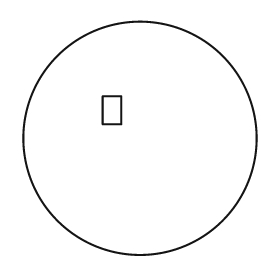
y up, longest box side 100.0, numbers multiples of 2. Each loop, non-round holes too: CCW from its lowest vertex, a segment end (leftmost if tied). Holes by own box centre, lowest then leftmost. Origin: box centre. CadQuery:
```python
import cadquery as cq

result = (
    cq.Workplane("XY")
    .moveTo(0.0, 0.0)
    .circle(50.0)
    .moveTo(-16.0, 6.0)
    .lineTo(-8.0, 6.0)
    .lineTo(-8.0, 18.0)
    .lineTo(-16.0, 18.0)
    .close()
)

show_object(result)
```